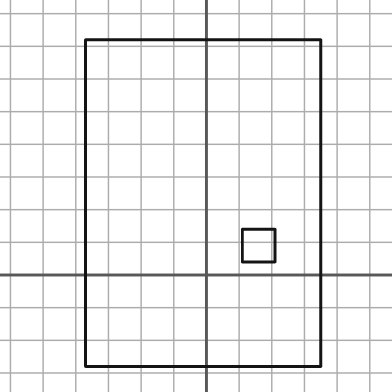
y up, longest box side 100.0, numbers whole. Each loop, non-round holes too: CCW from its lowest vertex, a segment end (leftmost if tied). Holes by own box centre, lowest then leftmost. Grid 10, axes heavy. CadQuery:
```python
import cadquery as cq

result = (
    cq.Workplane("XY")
    .moveTo(-37.0, -28.0)
    .lineTo(35.0, -28.0)
    .lineTo(35.0, 72.0)
    .lineTo(-37.0, 72.0)
    .close()
    .moveTo(11.0, 4.0)
    .lineTo(21.0, 4.0)
    .lineTo(21.0, 14.0)
    .lineTo(11.0, 14.0)
    .close()
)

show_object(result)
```